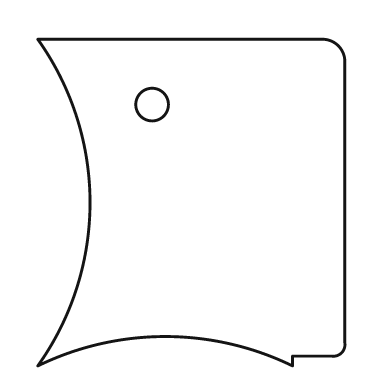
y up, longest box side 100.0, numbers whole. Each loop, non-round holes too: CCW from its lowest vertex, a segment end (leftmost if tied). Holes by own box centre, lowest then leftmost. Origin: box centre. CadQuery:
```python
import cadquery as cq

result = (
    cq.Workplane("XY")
    .moveTo(-47.0, -50.0)
    .threePointArc((-8.0, -41.0), (31.0, -50.0))
    .lineTo(31.0, -47.0)
    .lineTo(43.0, -47.0)
    .threePointArc((46.0, -46.0), (47.0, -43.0))
    .lineTo(47.0, 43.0)
    .threePointArc((45.0, 48.0), (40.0, 50.0))
    .lineTo(-47.0, 50.0)
    .threePointArc((-31.0, 0.0), (-47.0, -50.0))
    .close()
    .moveTo(-12.0, 30.0)
    .circle(5.0)
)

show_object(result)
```